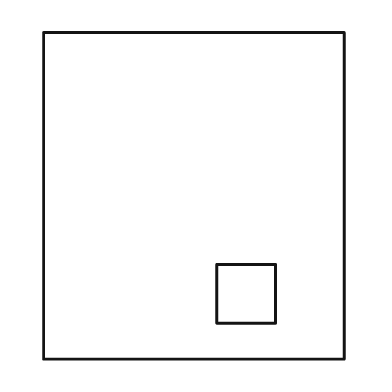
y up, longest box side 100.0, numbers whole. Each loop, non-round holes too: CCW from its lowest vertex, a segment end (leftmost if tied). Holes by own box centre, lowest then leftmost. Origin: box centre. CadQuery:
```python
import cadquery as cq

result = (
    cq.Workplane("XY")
    .moveTo(-46.0, -50.0)
    .lineTo(46.0, -50.0)
    .lineTo(46.0, 50.0)
    .lineTo(-46.0, 50.0)
    .close()
    .moveTo(7.0, -39.0)
    .lineTo(25.0, -39.0)
    .lineTo(25.0, -21.0)
    .lineTo(7.0, -21.0)
    .close()
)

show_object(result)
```